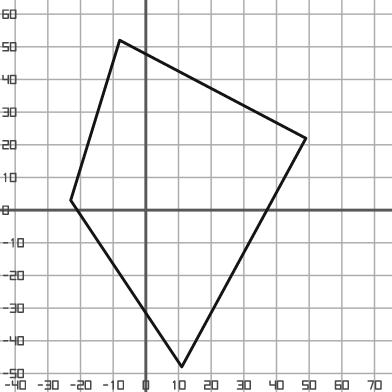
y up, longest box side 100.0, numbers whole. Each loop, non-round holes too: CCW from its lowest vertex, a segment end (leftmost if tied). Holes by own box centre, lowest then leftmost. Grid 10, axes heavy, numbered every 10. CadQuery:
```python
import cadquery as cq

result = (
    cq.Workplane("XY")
    .moveTo(11.0, -48.0)
    .lineTo(49.0, 22.0)
    .lineTo(-8.0, 52.0)
    .lineTo(-23.0, 3.0)
    .close()
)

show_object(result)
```